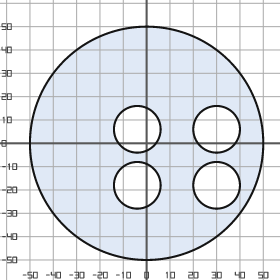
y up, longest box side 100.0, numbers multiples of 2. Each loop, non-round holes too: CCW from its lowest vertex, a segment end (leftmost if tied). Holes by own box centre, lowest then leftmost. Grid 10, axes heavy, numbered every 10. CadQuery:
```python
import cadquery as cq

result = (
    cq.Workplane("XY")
    .moveTo(0.0, 0.0)
    .circle(50.0)
    .moveTo(-4.0, -18.0)
    .circle(10.0)
    .moveTo(30.0, -18.0)
    .circle(10.0)
    .moveTo(-4.0, 6.0)
    .circle(10.0)
    .moveTo(30.0, 6.0)
    .circle(10.0)
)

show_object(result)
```